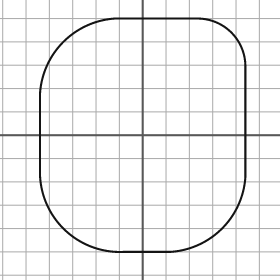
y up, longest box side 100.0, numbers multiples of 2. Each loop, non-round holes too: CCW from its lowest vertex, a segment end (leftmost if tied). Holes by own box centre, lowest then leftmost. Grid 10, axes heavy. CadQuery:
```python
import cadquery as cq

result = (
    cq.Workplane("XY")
    .moveTo(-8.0, -50.0)
    .lineTo(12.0, -50.0)
    .threePointArc((34.0, -40.0), (44.0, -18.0))
    .lineTo(44.0, 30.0)
    .threePointArc((38.0, 44.0), (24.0, 50.0))
    .lineTo(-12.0, 50.0)
    .threePointArc((-34.0, 40.0), (-44.0, 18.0))
    .lineTo(-44.0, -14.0)
    .threePointArc((-34.0, -40.0), (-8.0, -50.0))
    .close()
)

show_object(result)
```